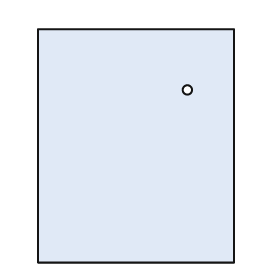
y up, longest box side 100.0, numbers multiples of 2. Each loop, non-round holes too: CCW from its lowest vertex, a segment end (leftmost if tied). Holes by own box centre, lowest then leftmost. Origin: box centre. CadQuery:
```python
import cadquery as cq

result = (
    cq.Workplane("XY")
    .moveTo(-42.0, -50.0)
    .lineTo(42.0, -50.0)
    .lineTo(42.0, 50.0)
    .lineTo(-42.0, 50.0)
    .close()
    .moveTo(22.0, 24.0)
    .circle(2.0)
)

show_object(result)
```